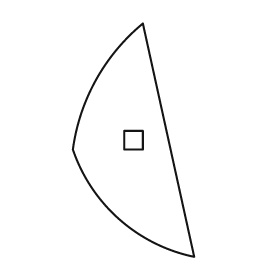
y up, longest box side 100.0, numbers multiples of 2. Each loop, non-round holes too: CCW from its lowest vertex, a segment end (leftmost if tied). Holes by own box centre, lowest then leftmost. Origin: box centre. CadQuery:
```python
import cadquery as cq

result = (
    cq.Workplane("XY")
    .moveTo(26.0, -50.0)
    .lineTo(4.0, 50.0)
    .threePointArc((-16.0, 26.0), (-26.0, -4.0))
    .threePointArc((-6.0, -34.0), (26.0, -50.0))
    .close()
    .moveTo(-4.0, -4.0)
    .lineTo(4.0, -4.0)
    .lineTo(4.0, 4.0)
    .lineTo(-4.0, 4.0)
    .close()
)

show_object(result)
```